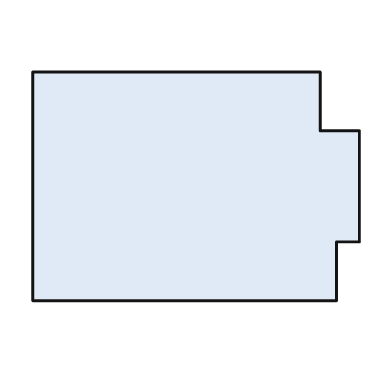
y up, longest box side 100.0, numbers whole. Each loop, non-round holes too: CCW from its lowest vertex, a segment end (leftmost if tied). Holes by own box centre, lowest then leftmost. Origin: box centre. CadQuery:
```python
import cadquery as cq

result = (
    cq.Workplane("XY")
    .moveTo(-50.0, -35.0)
    .lineTo(43.0, -35.0)
    .lineTo(43.0, -17.0)
    .lineTo(50.0, -17.0)
    .lineTo(50.0, 17.0)
    .lineTo(38.0, 17.0)
    .lineTo(38.0, 35.0)
    .lineTo(-50.0, 35.0)
    .close()
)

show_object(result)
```